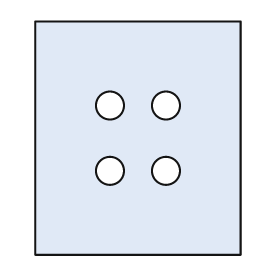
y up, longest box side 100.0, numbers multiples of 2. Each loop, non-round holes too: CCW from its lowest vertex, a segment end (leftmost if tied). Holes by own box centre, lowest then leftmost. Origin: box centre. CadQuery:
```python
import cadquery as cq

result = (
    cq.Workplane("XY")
    .moveTo(-44.0, -50.0)
    .lineTo(44.0, -50.0)
    .lineTo(44.0, 50.0)
    .lineTo(-44.0, 50.0)
    .close()
    .moveTo(-12.0, -14.0)
    .circle(6.0)
    .moveTo(12.0, -14.0)
    .circle(6.0)
    .moveTo(-12.0, 14.0)
    .circle(6.0)
    .moveTo(12.0, 14.0)
    .circle(6.0)
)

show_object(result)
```